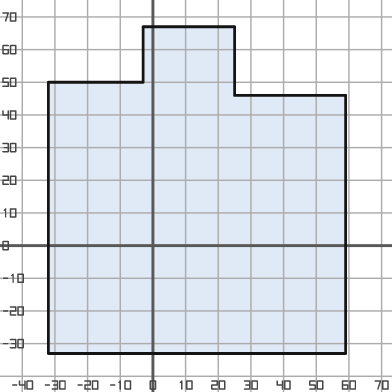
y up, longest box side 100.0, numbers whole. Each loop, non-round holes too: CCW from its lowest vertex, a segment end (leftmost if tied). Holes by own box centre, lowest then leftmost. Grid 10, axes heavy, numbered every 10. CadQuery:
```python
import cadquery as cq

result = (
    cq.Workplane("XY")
    .moveTo(-32.0, -33.0)
    .lineTo(59.0, -33.0)
    .lineTo(59.0, 46.0)
    .lineTo(25.0, 46.0)
    .lineTo(25.0, 67.0)
    .lineTo(-3.0, 67.0)
    .lineTo(-3.0, 50.0)
    .lineTo(-32.0, 50.0)
    .close()
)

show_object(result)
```